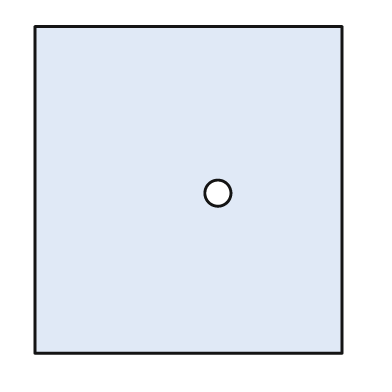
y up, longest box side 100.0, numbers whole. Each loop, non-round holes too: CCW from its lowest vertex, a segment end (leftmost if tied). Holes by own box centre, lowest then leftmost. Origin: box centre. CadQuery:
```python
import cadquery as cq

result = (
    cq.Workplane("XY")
    .moveTo(-47.0, -50.0)
    .lineTo(47.0, -50.0)
    .lineTo(47.0, 50.0)
    .lineTo(-47.0, 50.0)
    .close()
    .moveTo(9.0, -1.0)
    .circle(4.0)
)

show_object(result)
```